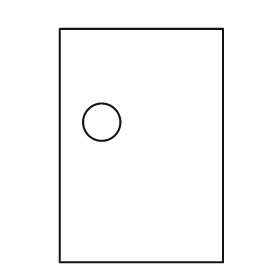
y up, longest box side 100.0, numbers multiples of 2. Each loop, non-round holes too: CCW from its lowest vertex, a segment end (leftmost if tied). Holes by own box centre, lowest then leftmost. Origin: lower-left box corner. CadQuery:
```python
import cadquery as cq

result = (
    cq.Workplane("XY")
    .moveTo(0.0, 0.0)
    .lineTo(70.0, 0.0)
    .lineTo(70.0, 100.0)
    .lineTo(0.0, 100.0)
    .close()
    .moveTo(18.0, 60.0)
    .circle(8.0)
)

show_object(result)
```